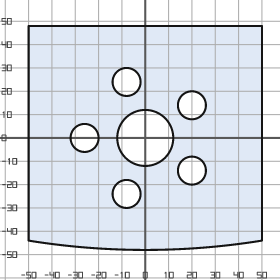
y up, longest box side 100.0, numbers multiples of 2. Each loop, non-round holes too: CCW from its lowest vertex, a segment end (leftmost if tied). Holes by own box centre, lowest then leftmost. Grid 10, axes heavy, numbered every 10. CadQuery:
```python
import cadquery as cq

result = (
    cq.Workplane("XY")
    .moveTo(-50.0, -44.0)
    .threePointArc((0.0, -48.0), (50.0, -44.0))
    .lineTo(50.0, 48.0)
    .lineTo(-50.0, 48.0)
    .close()
    .moveTo(-8.0, -24.0)
    .circle(6.0)
    .moveTo(20.0, -14.0)
    .circle(6.0)
    .moveTo(-26.0, 0.0)
    .circle(6.0)
    .moveTo(0.0, 0.0)
    .circle(12.0)
    .moveTo(20.0, 14.0)
    .circle(6.0)
    .moveTo(-8.0, 24.0)
    .circle(6.0)
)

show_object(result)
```